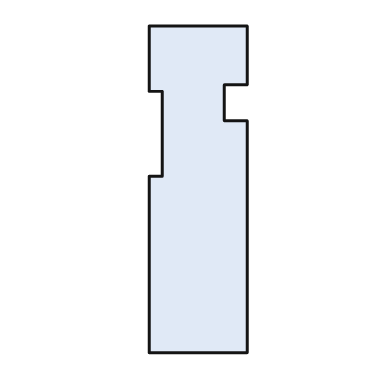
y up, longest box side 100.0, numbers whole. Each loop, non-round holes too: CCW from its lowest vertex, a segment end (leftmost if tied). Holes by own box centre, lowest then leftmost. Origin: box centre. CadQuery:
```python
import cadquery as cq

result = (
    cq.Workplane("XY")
    .moveTo(-15.0, -50.0)
    .lineTo(15.0, -50.0)
    .lineTo(15.0, 21.0)
    .lineTo(8.0, 21.0)
    .lineTo(8.0, 32.0)
    .lineTo(15.0, 32.0)
    .lineTo(15.0, 50.0)
    .lineTo(-15.0, 50.0)
    .lineTo(-15.0, 30.0)
    .lineTo(-11.0, 30.0)
    .lineTo(-11.0, 4.0)
    .lineTo(-15.0, 4.0)
    .close()
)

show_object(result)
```